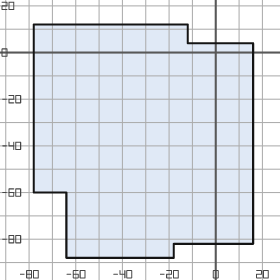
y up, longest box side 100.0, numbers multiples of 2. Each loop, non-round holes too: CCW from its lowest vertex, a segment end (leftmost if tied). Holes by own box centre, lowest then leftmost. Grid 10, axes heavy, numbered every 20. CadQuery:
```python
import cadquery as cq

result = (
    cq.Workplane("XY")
    .moveTo(-64.0, -88.0)
    .lineTo(-18.0, -88.0)
    .lineTo(-18.0, -82.0)
    .lineTo(16.0, -82.0)
    .lineTo(16.0, 4.0)
    .lineTo(-12.0, 4.0)
    .lineTo(-12.0, 12.0)
    .lineTo(-78.0, 12.0)
    .lineTo(-78.0, -60.0)
    .lineTo(-64.0, -60.0)
    .close()
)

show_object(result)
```